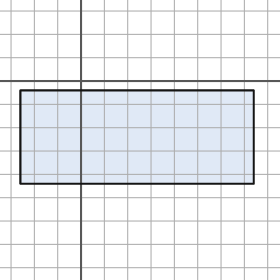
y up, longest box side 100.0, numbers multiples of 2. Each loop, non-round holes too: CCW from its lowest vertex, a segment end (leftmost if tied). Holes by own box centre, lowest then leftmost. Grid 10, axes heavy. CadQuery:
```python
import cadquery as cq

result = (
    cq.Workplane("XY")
    .moveTo(-26.0, -44.0)
    .lineTo(74.0, -44.0)
    .lineTo(74.0, -4.0)
    .lineTo(-26.0, -4.0)
    .close()
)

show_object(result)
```